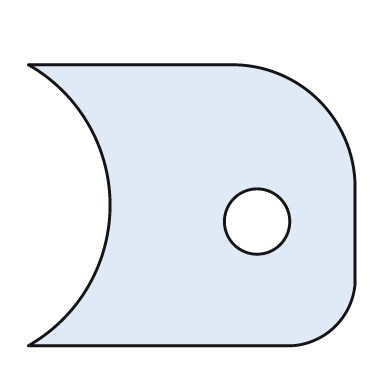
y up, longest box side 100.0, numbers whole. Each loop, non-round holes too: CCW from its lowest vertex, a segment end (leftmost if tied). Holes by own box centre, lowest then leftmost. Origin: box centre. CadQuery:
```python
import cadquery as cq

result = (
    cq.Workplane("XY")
    .moveTo(-50.0, -43.0)
    .lineTo(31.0, -43.0)
    .threePointArc((44.0, -37.0), (50.0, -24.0))
    .lineTo(50.0, 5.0)
    .threePointArc((39.0, 32.0), (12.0, 43.0))
    .lineTo(-50.0, 43.0)
    .threePointArc((-25.0, 0.0), (-50.0, -43.0))
    .close()
    .moveTo(20.0, -5.0)
    .circle(10.0)
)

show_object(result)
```